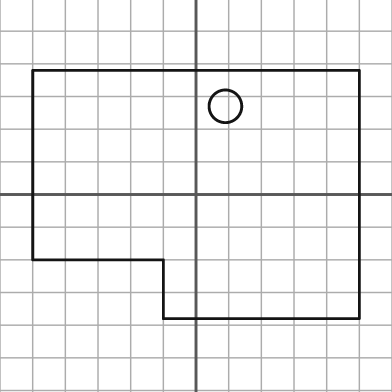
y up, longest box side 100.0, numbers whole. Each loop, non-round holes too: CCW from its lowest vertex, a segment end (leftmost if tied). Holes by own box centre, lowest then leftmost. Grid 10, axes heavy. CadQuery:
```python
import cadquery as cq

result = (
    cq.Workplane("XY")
    .moveTo(-10.0, -38.0)
    .lineTo(50.0, -38.0)
    .lineTo(50.0, 38.0)
    .lineTo(-50.0, 38.0)
    .lineTo(-50.0, -20.0)
    .lineTo(-10.0, -20.0)
    .close()
    .moveTo(9.0, 27.0)
    .circle(5.0)
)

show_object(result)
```